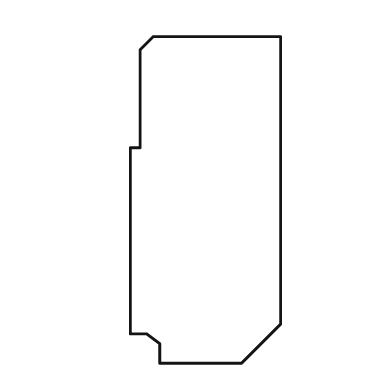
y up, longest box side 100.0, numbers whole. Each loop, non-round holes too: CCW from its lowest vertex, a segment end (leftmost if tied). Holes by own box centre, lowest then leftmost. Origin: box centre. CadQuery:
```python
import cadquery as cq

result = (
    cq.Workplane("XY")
    .moveTo(-14.0, -50.0)
    .lineTo(11.0, -50.0)
    .lineTo(23.0, -38.0)
    .lineTo(23.0, 50.0)
    .lineTo(-16.0, 50.0)
    .lineTo(-20.0, 46.0)
    .lineTo(-20.0, 16.0)
    .lineTo(-23.0, 16.0)
    .lineTo(-23.0, -41.0)
    .lineTo(-18.0, -41.0)
    .lineTo(-14.0, -44.0)
    .close()
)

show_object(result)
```